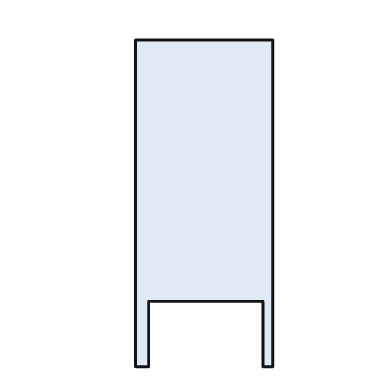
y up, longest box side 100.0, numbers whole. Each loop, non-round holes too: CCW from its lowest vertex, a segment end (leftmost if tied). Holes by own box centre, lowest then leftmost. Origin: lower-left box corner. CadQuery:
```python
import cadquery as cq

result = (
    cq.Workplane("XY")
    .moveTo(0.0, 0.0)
    .lineTo(4.0, 0.0)
    .lineTo(4.0, 20.0)
    .lineTo(39.0, 20.0)
    .lineTo(39.0, 0.0)
    .lineTo(42.0, 0.0)
    .lineTo(42.0, 100.0)
    .lineTo(0.0, 100.0)
    .close()
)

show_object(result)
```